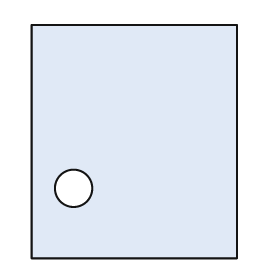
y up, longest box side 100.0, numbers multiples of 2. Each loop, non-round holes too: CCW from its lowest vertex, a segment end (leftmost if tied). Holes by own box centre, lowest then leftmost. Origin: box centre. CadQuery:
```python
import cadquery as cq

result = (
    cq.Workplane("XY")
    .moveTo(-44.0, -50.0)
    .lineTo(44.0, -50.0)
    .lineTo(44.0, 50.0)
    .lineTo(-44.0, 50.0)
    .close()
    .moveTo(-26.0, -20.0)
    .circle(8.0)
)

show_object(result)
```